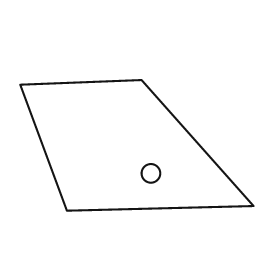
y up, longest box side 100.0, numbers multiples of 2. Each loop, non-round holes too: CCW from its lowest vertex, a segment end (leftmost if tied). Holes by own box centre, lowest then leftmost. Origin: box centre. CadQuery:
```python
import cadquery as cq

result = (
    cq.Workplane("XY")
    .moveTo(-30.0, -28.0)
    .lineTo(50.0, -26.0)
    .lineTo(2.0, 28.0)
    .lineTo(-50.0, 26.0)
    .close()
    .moveTo(6.0, -12.0)
    .circle(4.0)
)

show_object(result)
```